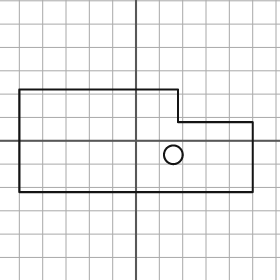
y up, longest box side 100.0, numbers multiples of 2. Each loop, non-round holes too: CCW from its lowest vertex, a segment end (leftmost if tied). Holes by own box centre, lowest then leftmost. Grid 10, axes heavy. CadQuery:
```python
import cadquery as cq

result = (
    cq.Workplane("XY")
    .moveTo(-50.0, -22.0)
    .lineTo(50.0, -22.0)
    .lineTo(50.0, 8.0)
    .lineTo(18.0, 8.0)
    .lineTo(18.0, 22.0)
    .lineTo(-50.0, 22.0)
    .close()
    .moveTo(16.0, -6.0)
    .circle(4.0)
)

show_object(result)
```